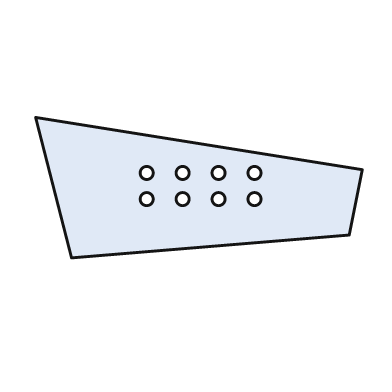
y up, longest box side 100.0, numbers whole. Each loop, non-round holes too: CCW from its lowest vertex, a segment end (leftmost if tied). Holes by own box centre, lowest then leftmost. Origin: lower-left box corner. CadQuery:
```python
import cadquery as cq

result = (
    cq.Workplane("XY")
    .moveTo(11.0, 0.0)
    .lineTo(96.0, 7.0)
    .lineTo(100.0, 27.0)
    .lineTo(0.0, 43.0)
    .close()
    .moveTo(34.0, 18.0)
    .circle(2.0)
    .moveTo(45.0, 18.0)
    .circle(2.0)
    .moveTo(56.0, 18.0)
    .circle(2.0)
    .moveTo(67.0, 18.0)
    .circle(2.0)
    .moveTo(34.0, 26.0)
    .circle(2.0)
    .moveTo(45.0, 26.0)
    .circle(2.0)
    .moveTo(56.0, 26.0)
    .circle(2.0)
    .moveTo(67.0, 26.0)
    .circle(2.0)
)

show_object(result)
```